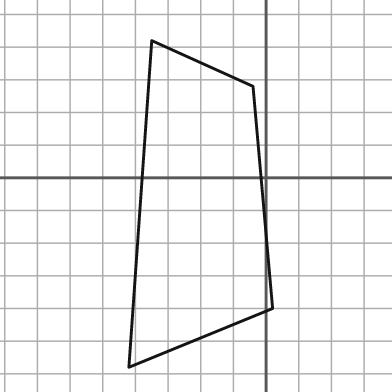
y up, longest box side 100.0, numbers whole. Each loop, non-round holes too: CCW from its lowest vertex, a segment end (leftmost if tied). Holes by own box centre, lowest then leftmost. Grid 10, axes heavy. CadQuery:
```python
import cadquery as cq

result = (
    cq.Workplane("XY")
    .moveTo(-42.0, -58.0)
    .lineTo(2.0, -40.0)
    .lineTo(-4.0, 28.0)
    .lineTo(-35.0, 42.0)
    .close()
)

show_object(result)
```